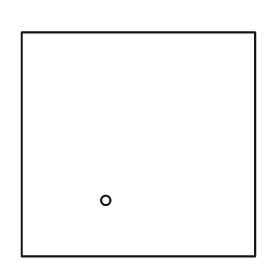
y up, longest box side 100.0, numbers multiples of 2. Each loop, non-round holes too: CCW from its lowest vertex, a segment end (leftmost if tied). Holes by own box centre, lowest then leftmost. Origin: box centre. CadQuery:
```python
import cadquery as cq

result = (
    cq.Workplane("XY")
    .moveTo(-50.0, -48.0)
    .lineTo(50.0, -48.0)
    .lineTo(50.0, 48.0)
    .lineTo(-50.0, 48.0)
    .close()
    .moveTo(-14.0, -24.0)
    .circle(2.0)
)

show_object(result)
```